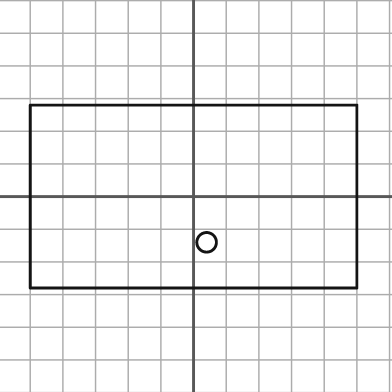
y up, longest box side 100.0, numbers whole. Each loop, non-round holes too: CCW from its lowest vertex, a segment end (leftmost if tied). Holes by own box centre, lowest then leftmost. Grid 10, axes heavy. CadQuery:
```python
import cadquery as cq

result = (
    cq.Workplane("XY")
    .moveTo(-50.0, -28.0)
    .lineTo(50.0, -28.0)
    .lineTo(50.0, 28.0)
    .lineTo(-50.0, 28.0)
    .close()
    .moveTo(4.0, -14.0)
    .circle(3.0)
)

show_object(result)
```